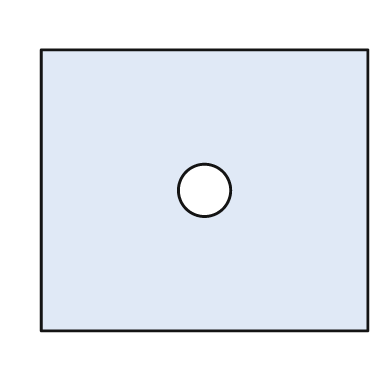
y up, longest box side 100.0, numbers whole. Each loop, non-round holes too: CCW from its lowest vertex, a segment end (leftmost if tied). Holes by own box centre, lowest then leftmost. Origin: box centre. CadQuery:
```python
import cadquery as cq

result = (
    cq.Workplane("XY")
    .moveTo(-50.0, -43.0)
    .lineTo(50.0, -43.0)
    .lineTo(50.0, 43.0)
    .lineTo(-50.0, 43.0)
    .close()
    .moveTo(0.0, 0.0)
    .circle(8.0)
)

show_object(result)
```